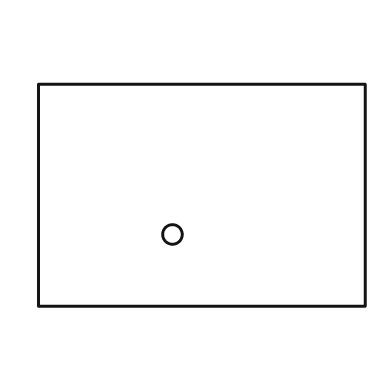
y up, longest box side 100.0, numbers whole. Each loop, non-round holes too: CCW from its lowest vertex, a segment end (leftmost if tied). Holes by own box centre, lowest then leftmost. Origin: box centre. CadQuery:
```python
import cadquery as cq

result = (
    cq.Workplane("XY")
    .moveTo(-50.0, -34.0)
    .lineTo(50.0, -34.0)
    .lineTo(50.0, 34.0)
    .lineTo(-50.0, 34.0)
    .close()
    .moveTo(-9.0, -12.0)
    .circle(3.0)
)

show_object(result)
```